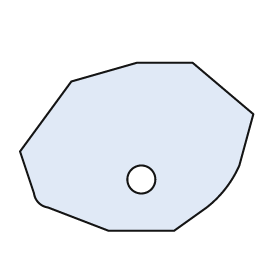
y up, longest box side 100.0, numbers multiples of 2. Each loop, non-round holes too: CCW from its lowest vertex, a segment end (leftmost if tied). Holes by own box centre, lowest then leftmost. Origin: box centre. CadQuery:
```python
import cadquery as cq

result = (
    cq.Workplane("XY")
    .moveTo(-12.0, -36.0)
    .lineTo(16.0, -36.0)
    .lineTo(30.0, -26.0)
    .threePointArc((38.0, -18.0), (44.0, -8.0))
    .lineTo(50.0, 14.0)
    .lineTo(24.0, 36.0)
    .lineTo(0.0, 36.0)
    .lineTo(-28.0, 28.0)
    .lineTo(-50.0, -2.0)
    .lineTo(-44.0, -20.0)
    .threePointArc((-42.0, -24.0), (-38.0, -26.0))
    .close()
    .moveTo(2.0, -14.0)
    .circle(6.0)
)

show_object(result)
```